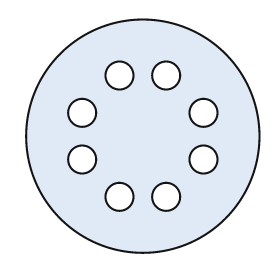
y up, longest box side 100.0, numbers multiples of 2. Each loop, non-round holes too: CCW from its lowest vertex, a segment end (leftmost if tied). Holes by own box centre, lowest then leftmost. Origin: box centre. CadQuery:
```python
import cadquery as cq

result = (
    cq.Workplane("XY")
    .moveTo(0.0, 0.0)
    .circle(50.0)
    .moveTo(-10.0, -26.0)
    .circle(6.0)
    .moveTo(10.0, -26.0)
    .circle(6.0)
    .moveTo(-26.0, -10.0)
    .circle(6.0)
    .moveTo(26.0, -10.0)
    .circle(6.0)
    .moveTo(-26.0, 10.0)
    .circle(6.0)
    .moveTo(26.0, 10.0)
    .circle(6.0)
    .moveTo(-10.0, 26.0)
    .circle(6.0)
    .moveTo(10.0, 26.0)
    .circle(6.0)
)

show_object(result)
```